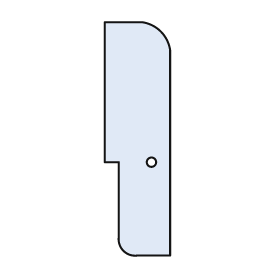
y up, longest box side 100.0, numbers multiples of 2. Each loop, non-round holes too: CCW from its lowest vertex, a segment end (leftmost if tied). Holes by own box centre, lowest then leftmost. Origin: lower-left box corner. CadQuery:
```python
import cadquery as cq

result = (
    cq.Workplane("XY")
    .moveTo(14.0, 0.0)
    .lineTo(28.0, 0.0)
    .lineTo(28.0, 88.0)
    .threePointArc((24.0, 96.0), (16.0, 100.0))
    .lineTo(0.0, 100.0)
    .lineTo(0.0, 40.0)
    .lineTo(6.0, 40.0)
    .lineTo(6.0, 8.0)
    .threePointArc((8.0, 2.0), (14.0, 0.0))
    .close()
    .moveTo(20.0, 40.0)
    .circle(2.0)
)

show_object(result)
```